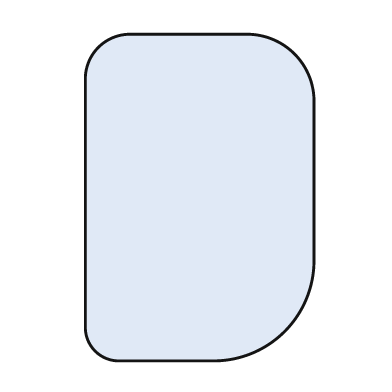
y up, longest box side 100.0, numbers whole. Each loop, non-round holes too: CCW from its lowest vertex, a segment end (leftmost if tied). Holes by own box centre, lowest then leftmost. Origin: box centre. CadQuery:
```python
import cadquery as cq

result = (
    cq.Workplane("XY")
    .moveTo(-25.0, -50.0)
    .lineTo(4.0, -50.0)
    .threePointArc((26.0, -41.0), (35.0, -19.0))
    .lineTo(35.0, 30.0)
    .threePointArc((29.0, 44.0), (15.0, 50.0))
    .lineTo(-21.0, 50.0)
    .threePointArc((-31.0, 46.0), (-35.0, 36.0))
    .lineTo(-35.0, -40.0)
    .threePointArc((-32.0, -47.0), (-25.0, -50.0))
    .close()
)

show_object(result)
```